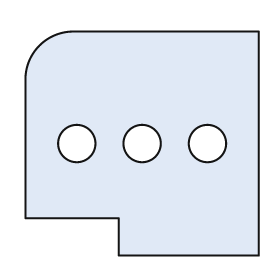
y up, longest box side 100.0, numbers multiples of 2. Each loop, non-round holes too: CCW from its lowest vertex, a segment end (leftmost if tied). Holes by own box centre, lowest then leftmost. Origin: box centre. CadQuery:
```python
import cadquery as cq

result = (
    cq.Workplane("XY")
    .moveTo(-10.0, -48.0)
    .lineTo(50.0, -48.0)
    .lineTo(50.0, 48.0)
    .lineTo(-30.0, 48.0)
    .threePointArc((-44.0, 42.0), (-50.0, 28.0))
    .lineTo(-50.0, -32.0)
    .lineTo(-10.0, -32.0)
    .close()
    .moveTo(-28.0, 0.0)
    .circle(8.0)
    .moveTo(0.0, 0.0)
    .circle(8.0)
    .moveTo(28.0, 0.0)
    .circle(8.0)
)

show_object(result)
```